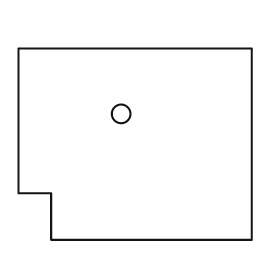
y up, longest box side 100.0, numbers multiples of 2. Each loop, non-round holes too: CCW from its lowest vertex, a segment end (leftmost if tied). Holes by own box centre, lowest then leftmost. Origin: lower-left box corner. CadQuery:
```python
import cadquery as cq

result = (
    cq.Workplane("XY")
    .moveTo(14.0, 0.0)
    .lineTo(100.0, 0.0)
    .lineTo(100.0, 82.0)
    .lineTo(0.0, 82.0)
    .lineTo(0.0, 20.0)
    .lineTo(14.0, 20.0)
    .close()
    .moveTo(44.0, 54.0)
    .circle(4.0)
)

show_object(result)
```